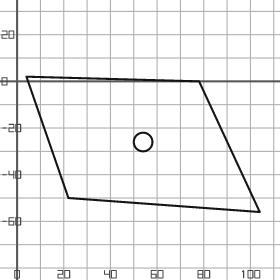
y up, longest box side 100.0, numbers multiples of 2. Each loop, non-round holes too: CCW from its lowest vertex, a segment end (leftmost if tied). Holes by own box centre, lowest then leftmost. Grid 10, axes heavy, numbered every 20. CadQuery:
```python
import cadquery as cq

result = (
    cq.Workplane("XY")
    .moveTo(104.0, -56.0)
    .lineTo(78.0, 0.0)
    .lineTo(4.0, 2.0)
    .lineTo(22.0, -50.0)
    .close()
    .moveTo(54.0, -26.0)
    .circle(4.0)
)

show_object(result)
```